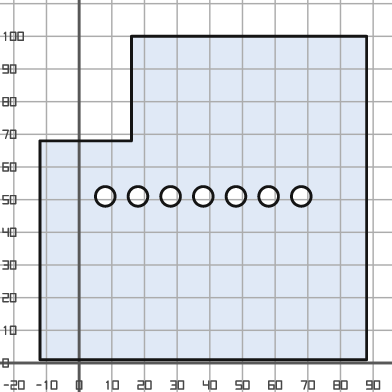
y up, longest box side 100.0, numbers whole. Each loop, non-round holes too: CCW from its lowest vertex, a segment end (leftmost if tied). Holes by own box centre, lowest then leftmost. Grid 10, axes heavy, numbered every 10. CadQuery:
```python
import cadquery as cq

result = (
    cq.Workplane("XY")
    .moveTo(-12.0, 1.0)
    .lineTo(88.0, 1.0)
    .lineTo(88.0, 100.0)
    .lineTo(16.0, 100.0)
    .lineTo(16.0, 68.0)
    .lineTo(-12.0, 68.0)
    .close()
    .moveTo(8.0, 51.0)
    .circle(3.0)
    .moveTo(18.0, 51.0)
    .circle(3.0)
    .moveTo(28.0, 51.0)
    .circle(3.0)
    .moveTo(38.0, 51.0)
    .circle(3.0)
    .moveTo(48.0, 51.0)
    .circle(3.0)
    .moveTo(58.0, 51.0)
    .circle(3.0)
    .moveTo(68.0, 51.0)
    .circle(3.0)
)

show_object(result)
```